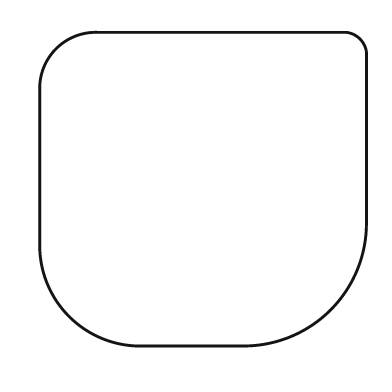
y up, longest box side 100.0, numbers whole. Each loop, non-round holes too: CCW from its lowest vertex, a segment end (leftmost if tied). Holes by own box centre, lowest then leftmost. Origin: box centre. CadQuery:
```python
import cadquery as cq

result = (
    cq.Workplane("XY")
    .moveTo(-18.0, -48.0)
    .lineTo(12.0, -48.0)
    .threePointArc((39.0, -37.0), (50.0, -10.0))
    .lineTo(50.0, 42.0)
    .threePointArc((48.0, 46.0), (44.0, 48.0))
    .lineTo(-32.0, 48.0)
    .threePointArc((-45.0, 43.0), (-50.0, 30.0))
    .lineTo(-50.0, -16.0)
    .threePointArc((-41.0, -39.0), (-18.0, -48.0))
    .close()
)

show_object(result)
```